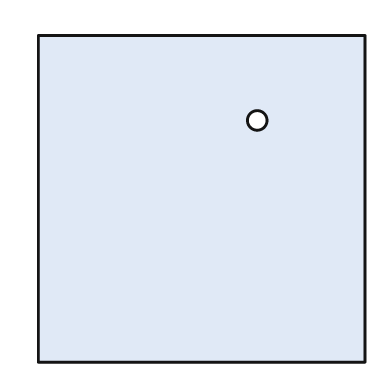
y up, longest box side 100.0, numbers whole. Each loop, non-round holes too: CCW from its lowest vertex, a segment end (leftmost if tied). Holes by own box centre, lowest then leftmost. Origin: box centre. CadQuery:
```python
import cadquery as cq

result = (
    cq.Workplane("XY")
    .moveTo(-50.0, -50.0)
    .lineTo(50.0, -50.0)
    .lineTo(50.0, 50.0)
    .lineTo(-50.0, 50.0)
    .close()
    .moveTo(17.0, 24.0)
    .circle(3.0)
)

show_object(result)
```